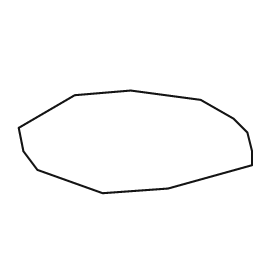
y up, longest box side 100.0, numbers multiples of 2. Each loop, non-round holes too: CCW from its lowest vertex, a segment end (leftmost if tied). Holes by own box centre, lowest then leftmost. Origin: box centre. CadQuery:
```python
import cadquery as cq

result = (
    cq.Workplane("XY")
    .moveTo(-14.0, -22.0)
    .lineTo(14.0, -20.0)
    .lineTo(50.0, -10.0)
    .lineTo(50.0, -4.0)
    .lineTo(48.0, 4.0)
    .lineTo(42.0, 10.0)
    .lineTo(28.0, 18.0)
    .lineTo(-2.0, 22.0)
    .lineTo(-26.0, 20.0)
    .lineTo(-50.0, 6.0)
    .lineTo(-48.0, -4.0)
    .lineTo(-42.0, -12.0)
    .close()
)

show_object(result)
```